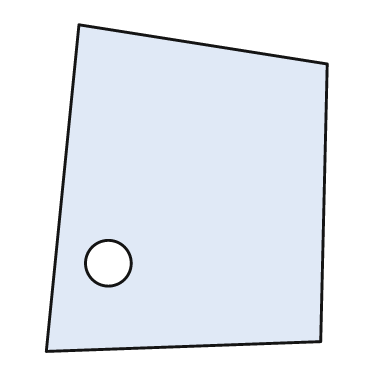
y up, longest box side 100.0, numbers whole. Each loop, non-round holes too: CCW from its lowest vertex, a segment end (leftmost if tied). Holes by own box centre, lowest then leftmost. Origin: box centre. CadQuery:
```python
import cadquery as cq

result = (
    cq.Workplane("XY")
    .moveTo(-43.0, -50.0)
    .lineTo(41.0, -47.0)
    .lineTo(43.0, 38.0)
    .lineTo(-33.0, 50.0)
    .close()
    .moveTo(-24.0, -23.0)
    .circle(7.0)
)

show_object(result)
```